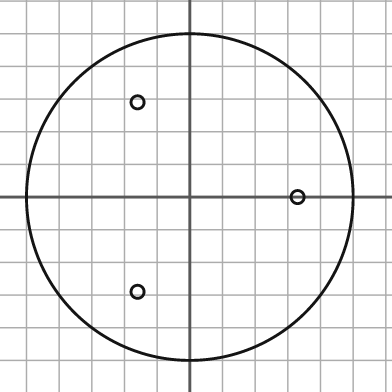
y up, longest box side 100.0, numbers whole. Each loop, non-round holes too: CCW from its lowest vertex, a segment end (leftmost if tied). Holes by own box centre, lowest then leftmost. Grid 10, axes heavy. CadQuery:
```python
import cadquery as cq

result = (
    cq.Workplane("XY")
    .moveTo(0.0, 0.0)
    .circle(50.0)
    .moveTo(-16.0, -29.0)
    .circle(2.0)
    .moveTo(33.0, 0.0)
    .circle(2.0)
    .moveTo(-16.0, 29.0)
    .circle(2.0)
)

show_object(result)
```